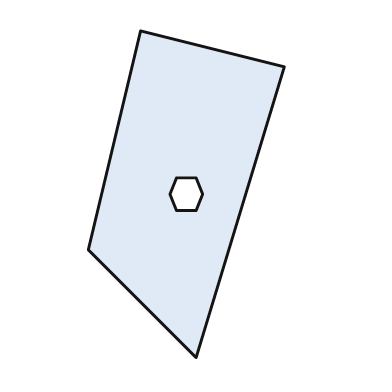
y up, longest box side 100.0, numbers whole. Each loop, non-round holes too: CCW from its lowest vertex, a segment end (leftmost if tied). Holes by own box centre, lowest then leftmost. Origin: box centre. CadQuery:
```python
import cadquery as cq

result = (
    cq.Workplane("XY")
    .moveTo(3.0, -50.0)
    .lineTo(30.0, 39.0)
    .lineTo(-14.0, 50.0)
    .lineTo(-30.0, -17.0)
    .close()
    .moveTo(-3.0, -5.0)
    .lineTo(3.0, -5.0)
    .lineTo(5.0, 0.0)
    .lineTo(3.0, 5.0)
    .lineTo(-3.0, 5.0)
    .lineTo(-5.0, 0.0)
    .close()
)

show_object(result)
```